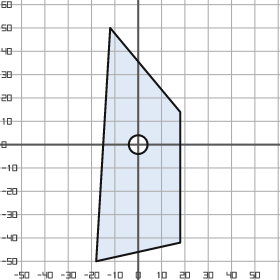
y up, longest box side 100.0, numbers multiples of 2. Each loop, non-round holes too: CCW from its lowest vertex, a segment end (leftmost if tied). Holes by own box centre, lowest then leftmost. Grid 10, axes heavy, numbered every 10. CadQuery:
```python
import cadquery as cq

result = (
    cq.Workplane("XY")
    .moveTo(-18.0, -50.0)
    .lineTo(18.0, -42.0)
    .lineTo(18.0, 14.0)
    .lineTo(-12.0, 50.0)
    .close()
    .moveTo(0.0, 0.0)
    .circle(4.0)
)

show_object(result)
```